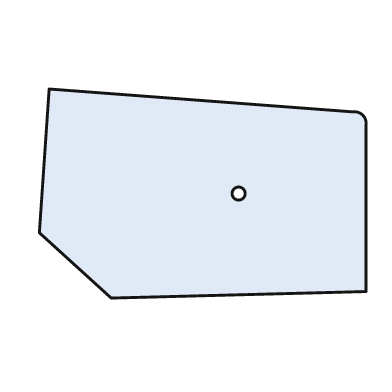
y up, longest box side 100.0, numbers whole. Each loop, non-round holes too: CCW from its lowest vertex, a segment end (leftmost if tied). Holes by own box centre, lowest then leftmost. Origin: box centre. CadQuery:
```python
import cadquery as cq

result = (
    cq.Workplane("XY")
    .moveTo(-28.0, -32.0)
    .lineTo(50.0, -30.0)
    .lineTo(50.0, 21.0)
    .threePointArc((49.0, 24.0), (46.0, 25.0))
    .lineTo(-47.0, 32.0)
    .lineTo(-50.0, -12.0)
    .close()
    .moveTo(11.0, 0.0)
    .circle(2.0)
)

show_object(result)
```